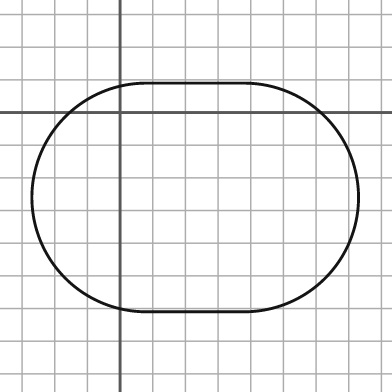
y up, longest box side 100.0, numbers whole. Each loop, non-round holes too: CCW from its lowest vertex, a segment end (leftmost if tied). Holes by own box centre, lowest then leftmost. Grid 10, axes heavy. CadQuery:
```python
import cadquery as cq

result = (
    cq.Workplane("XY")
    .moveTo(8.0, -61.0)
    .lineTo(38.0, -61.0)
    .threePointArc((73.0, -26.0), (38.0, 9.0))
    .lineTo(8.0, 9.0)
    .threePointArc((-27.0, -26.0), (8.0, -61.0))
    .close()
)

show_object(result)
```